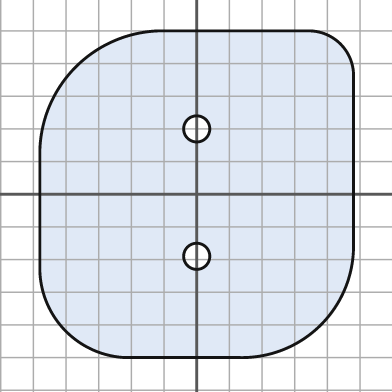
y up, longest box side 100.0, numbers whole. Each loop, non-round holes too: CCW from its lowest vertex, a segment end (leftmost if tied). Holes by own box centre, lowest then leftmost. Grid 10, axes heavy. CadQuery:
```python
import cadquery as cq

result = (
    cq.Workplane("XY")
    .moveTo(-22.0, -50.0)
    .lineTo(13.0, -50.0)
    .threePointArc((38.0, -40.0), (48.0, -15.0))
    .lineTo(48.0, 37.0)
    .threePointArc((44.0, 46.0), (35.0, 50.0))
    .lineTo(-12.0, 50.0)
    .threePointArc((-37.0, 39.0), (-48.0, 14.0))
    .lineTo(-48.0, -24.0)
    .threePointArc((-40.0, -42.0), (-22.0, -50.0))
    .close()
    .moveTo(0.0, -19.0)
    .circle(4.0)
    .moveTo(0.0, 20.0)
    .circle(4.0)
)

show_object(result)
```